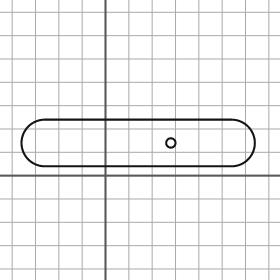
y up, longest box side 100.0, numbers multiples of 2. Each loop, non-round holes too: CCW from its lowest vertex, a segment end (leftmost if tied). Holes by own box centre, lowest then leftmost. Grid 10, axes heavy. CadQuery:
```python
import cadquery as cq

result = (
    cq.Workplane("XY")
    .moveTo(-26.0, 4.0)
    .lineTo(54.0, 4.0)
    .threePointArc((64.0, 14.0), (54.0, 24.0))
    .lineTo(-26.0, 24.0)
    .threePointArc((-36.0, 14.0), (-26.0, 4.0))
    .close()
    .moveTo(28.0, 14.0)
    .circle(2.0)
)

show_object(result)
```